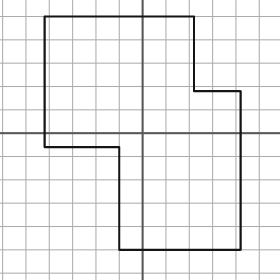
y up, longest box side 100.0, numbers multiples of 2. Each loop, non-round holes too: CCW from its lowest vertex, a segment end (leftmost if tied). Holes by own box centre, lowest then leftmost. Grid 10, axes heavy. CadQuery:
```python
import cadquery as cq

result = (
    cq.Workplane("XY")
    .moveTo(-10.0, -50.0)
    .lineTo(42.0, -50.0)
    .lineTo(42.0, 18.0)
    .lineTo(22.0, 18.0)
    .lineTo(22.0, 50.0)
    .lineTo(-42.0, 50.0)
    .lineTo(-42.0, -6.0)
    .lineTo(-10.0, -6.0)
    .close()
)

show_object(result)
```